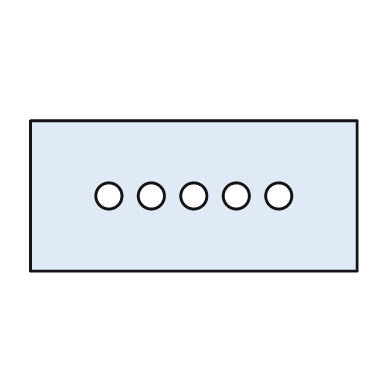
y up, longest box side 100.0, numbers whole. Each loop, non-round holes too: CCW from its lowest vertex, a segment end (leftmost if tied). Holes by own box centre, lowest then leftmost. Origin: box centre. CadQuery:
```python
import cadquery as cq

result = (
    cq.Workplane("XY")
    .moveTo(-50.0, -23.0)
    .lineTo(50.0, -23.0)
    .lineTo(50.0, 23.0)
    .lineTo(-50.0, 23.0)
    .close()
    .moveTo(-26.0, 0.0)
    .circle(4.0)
    .moveTo(-13.0, 0.0)
    .circle(4.0)
    .moveTo(0.0, 0.0)
    .circle(4.0)
    .moveTo(13.0, 0.0)
    .circle(4.0)
    .moveTo(26.0, 0.0)
    .circle(4.0)
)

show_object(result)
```